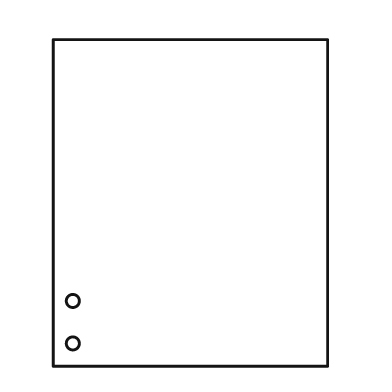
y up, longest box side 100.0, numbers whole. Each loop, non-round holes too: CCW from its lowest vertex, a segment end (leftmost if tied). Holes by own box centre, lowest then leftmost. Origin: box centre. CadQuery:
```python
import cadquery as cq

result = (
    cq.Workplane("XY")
    .moveTo(-42.0, -50.0)
    .lineTo(42.0, -50.0)
    .lineTo(42.0, 50.0)
    .lineTo(-42.0, 50.0)
    .close()
    .moveTo(-36.0, -43.0)
    .circle(2.0)
    .moveTo(-36.0, -30.0)
    .circle(2.0)
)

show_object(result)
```